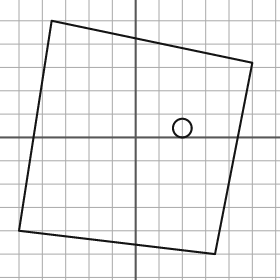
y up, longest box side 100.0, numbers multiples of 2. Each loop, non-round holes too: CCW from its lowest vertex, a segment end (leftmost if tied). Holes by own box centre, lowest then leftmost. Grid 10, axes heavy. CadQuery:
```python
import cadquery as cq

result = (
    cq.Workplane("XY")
    .moveTo(34.0, -50.0)
    .lineTo(50.0, 32.0)
    .lineTo(-36.0, 50.0)
    .lineTo(-50.0, -40.0)
    .close()
    .moveTo(20.0, 4.0)
    .circle(4.0)
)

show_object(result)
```